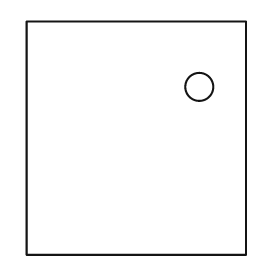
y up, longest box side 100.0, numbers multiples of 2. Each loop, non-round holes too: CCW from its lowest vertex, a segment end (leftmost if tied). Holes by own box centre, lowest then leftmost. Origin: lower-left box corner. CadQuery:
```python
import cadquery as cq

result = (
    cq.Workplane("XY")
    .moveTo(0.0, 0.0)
    .lineTo(94.0, 0.0)
    .lineTo(94.0, 100.0)
    .lineTo(0.0, 100.0)
    .close()
    .moveTo(74.0, 72.0)
    .circle(6.0)
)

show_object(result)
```